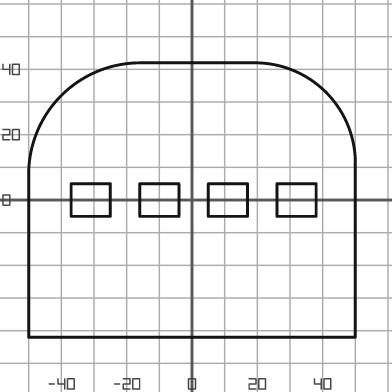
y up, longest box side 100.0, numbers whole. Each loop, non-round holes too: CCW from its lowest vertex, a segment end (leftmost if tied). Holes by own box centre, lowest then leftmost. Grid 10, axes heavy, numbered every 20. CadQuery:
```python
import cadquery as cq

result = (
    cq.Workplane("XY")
    .moveTo(-50.0, -42.0)
    .lineTo(50.0, -42.0)
    .lineTo(50.0, 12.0)
    .threePointArc((41.0, 33.0), (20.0, 42.0))
    .lineTo(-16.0, 42.0)
    .threePointArc((-40.0, 32.0), (-50.0, 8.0))
    .close()
    .moveTo(-37.0, -5.0)
    .lineTo(-25.0, -5.0)
    .lineTo(-25.0, 5.0)
    .lineTo(-37.0, 5.0)
    .close()
    .moveTo(-16.0, -5.0)
    .lineTo(-4.0, -5.0)
    .lineTo(-4.0, 5.0)
    .lineTo(-16.0, 5.0)
    .close()
    .moveTo(5.0, -5.0)
    .lineTo(17.0, -5.0)
    .lineTo(17.0, 5.0)
    .lineTo(5.0, 5.0)
    .close()
    .moveTo(26.0, -5.0)
    .lineTo(38.0, -5.0)
    .lineTo(38.0, 5.0)
    .lineTo(26.0, 5.0)
    .close()
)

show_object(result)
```